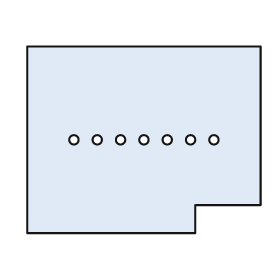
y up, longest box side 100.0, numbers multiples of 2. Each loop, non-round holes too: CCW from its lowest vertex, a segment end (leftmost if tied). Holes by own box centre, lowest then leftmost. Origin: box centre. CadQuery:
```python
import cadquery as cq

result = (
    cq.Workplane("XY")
    .moveTo(-50.0, -40.0)
    .lineTo(22.0, -40.0)
    .lineTo(22.0, -28.0)
    .lineTo(50.0, -28.0)
    .lineTo(50.0, 40.0)
    .lineTo(-50.0, 40.0)
    .close()
    .moveTo(-30.0, 0.0)
    .circle(2.0)
    .moveTo(-20.0, 0.0)
    .circle(2.0)
    .moveTo(-10.0, 0.0)
    .circle(2.0)
    .moveTo(0.0, 0.0)
    .circle(2.0)
    .moveTo(10.0, 0.0)
    .circle(2.0)
    .moveTo(20.0, 0.0)
    .circle(2.0)
    .moveTo(30.0, 0.0)
    .circle(2.0)
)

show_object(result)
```